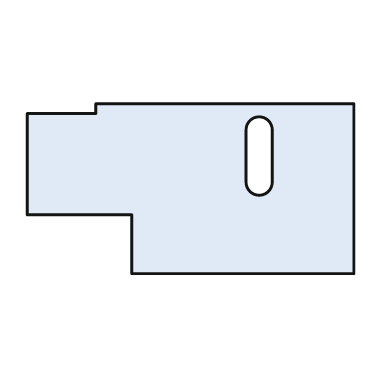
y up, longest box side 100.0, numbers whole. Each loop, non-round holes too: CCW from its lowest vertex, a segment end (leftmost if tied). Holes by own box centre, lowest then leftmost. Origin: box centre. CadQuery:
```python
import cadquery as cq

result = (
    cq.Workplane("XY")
    .moveTo(-18.0, -26.0)
    .lineTo(50.0, -26.0)
    .lineTo(50.0, 26.0)
    .lineTo(-29.0, 26.0)
    .lineTo(-29.0, 23.0)
    .lineTo(-50.0, 23.0)
    .lineTo(-50.0, -8.0)
    .lineTo(-18.0, -8.0)
    .close()
    .moveTo(17.0, 2.0)
    .threePointArc((21.0, -2.0), (25.0, 2.0))
    .lineTo(25.0, 18.0)
    .threePointArc((21.0, 22.0), (17.0, 18.0))
    .close()
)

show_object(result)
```